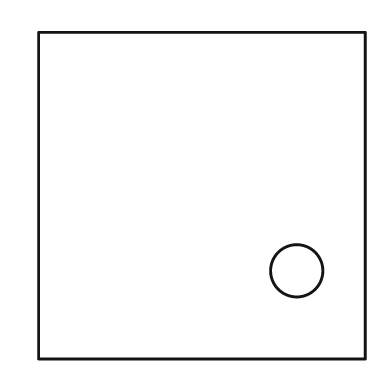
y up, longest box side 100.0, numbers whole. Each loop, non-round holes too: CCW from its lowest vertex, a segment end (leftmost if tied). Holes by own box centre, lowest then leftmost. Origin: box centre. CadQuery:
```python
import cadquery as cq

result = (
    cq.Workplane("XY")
    .moveTo(-50.0, -50.0)
    .lineTo(50.0, -50.0)
    .lineTo(50.0, 50.0)
    .lineTo(-50.0, 50.0)
    .close()
    .moveTo(29.0, -23.0)
    .circle(8.0)
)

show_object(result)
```